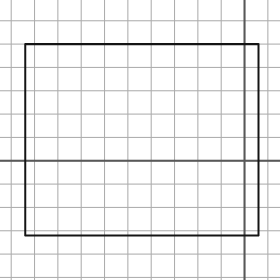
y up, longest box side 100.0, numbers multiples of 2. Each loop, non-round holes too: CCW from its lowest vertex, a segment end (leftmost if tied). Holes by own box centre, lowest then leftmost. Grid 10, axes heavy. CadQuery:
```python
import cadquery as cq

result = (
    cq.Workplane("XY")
    .moveTo(-94.0, -32.0)
    .lineTo(6.0, -32.0)
    .lineTo(6.0, 50.0)
    .lineTo(-94.0, 50.0)
    .close()
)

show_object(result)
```